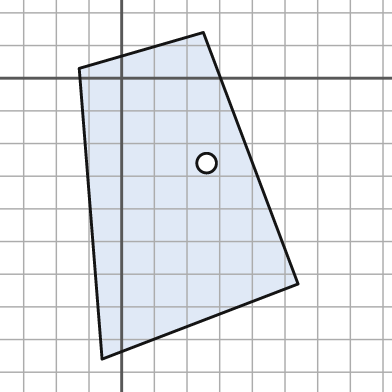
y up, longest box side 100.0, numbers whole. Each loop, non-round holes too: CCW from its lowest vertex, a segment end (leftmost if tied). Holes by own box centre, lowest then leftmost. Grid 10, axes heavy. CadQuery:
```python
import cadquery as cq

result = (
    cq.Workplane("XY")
    .moveTo(-6.0, -86.0)
    .lineTo(54.0, -63.0)
    .lineTo(25.0, 14.0)
    .lineTo(-13.0, 3.0)
    .close()
    .moveTo(26.0, -26.0)
    .circle(3.0)
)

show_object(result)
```